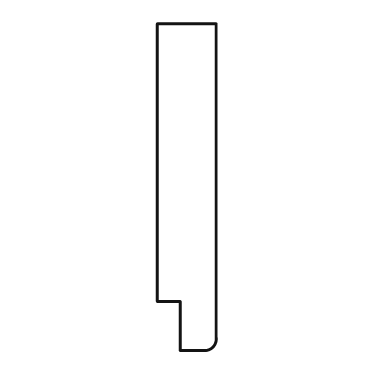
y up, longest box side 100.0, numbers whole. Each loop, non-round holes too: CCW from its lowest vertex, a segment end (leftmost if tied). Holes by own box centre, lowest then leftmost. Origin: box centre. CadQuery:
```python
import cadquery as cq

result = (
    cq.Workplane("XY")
    .moveTo(-2.0, -50.0)
    .lineTo(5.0, -50.0)
    .threePointArc((8.0, -49.0), (9.0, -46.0))
    .lineTo(9.0, 50.0)
    .lineTo(-9.0, 50.0)
    .lineTo(-9.0, -35.0)
    .lineTo(-2.0, -35.0)
    .close()
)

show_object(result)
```